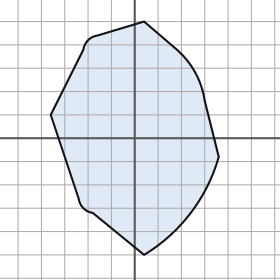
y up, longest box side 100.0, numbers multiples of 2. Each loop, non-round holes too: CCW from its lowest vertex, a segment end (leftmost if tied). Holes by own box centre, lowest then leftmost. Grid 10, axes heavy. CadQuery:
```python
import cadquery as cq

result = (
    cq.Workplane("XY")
    .moveTo(4.0, -50.0)
    .threePointArc((24.0, -32.0), (36.0, -8.0))
    .lineTo(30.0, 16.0)
    .threePointArc((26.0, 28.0), (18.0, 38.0))
    .lineTo(4.0, 50.0)
    .lineTo(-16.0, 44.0)
    .threePointArc((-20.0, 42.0), (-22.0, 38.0))
    .lineTo(-36.0, 10.0)
    .lineTo(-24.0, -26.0)
    .threePointArc((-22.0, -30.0), (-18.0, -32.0))
    .close()
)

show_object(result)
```